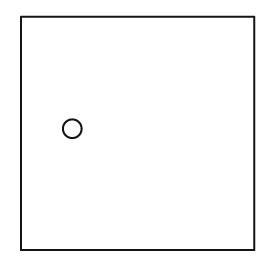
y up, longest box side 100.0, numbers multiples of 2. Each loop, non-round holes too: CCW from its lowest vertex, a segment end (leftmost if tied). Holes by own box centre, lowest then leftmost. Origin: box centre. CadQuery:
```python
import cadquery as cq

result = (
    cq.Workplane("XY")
    .moveTo(-50.0, -50.0)
    .lineTo(50.0, -50.0)
    .lineTo(50.0, 50.0)
    .lineTo(-50.0, 50.0)
    .close()
    .moveTo(-28.0, 2.0)
    .circle(4.0)
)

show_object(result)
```